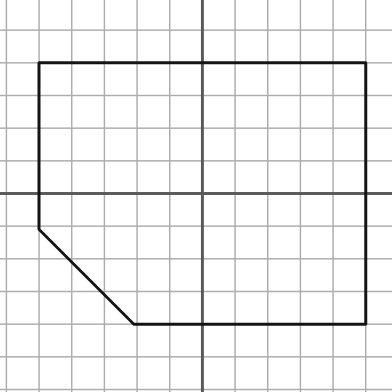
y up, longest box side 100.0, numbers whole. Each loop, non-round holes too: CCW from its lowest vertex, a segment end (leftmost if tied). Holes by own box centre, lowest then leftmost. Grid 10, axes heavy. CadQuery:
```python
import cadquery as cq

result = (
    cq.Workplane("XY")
    .moveTo(-21.0, -40.0)
    .lineTo(50.0, -40.0)
    .lineTo(50.0, 40.0)
    .lineTo(-50.0, 40.0)
    .lineTo(-50.0, -11.0)
    .close()
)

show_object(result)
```